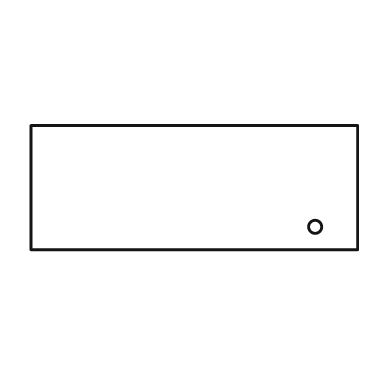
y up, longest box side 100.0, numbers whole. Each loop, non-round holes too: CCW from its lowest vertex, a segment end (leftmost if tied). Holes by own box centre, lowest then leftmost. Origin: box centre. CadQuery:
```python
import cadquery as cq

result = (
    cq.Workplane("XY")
    .moveTo(-50.0, -19.0)
    .lineTo(50.0, -19.0)
    .lineTo(50.0, 19.0)
    .lineTo(-50.0, 19.0)
    .close()
    .moveTo(37.0, -12.0)
    .circle(2.0)
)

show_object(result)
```